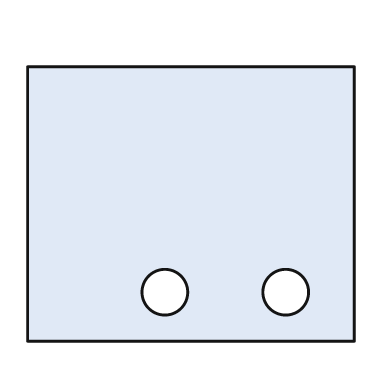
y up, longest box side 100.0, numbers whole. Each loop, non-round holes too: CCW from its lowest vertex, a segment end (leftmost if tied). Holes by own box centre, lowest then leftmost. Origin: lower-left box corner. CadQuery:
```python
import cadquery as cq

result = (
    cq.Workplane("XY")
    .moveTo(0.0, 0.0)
    .lineTo(100.0, 0.0)
    .lineTo(100.0, 84.0)
    .lineTo(0.0, 84.0)
    .close()
    .moveTo(42.0, 15.0)
    .circle(7.0)
    .moveTo(79.0, 15.0)
    .circle(7.0)
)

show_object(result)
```